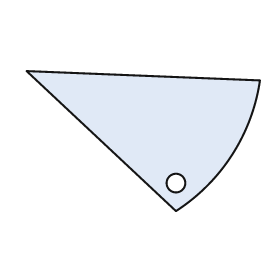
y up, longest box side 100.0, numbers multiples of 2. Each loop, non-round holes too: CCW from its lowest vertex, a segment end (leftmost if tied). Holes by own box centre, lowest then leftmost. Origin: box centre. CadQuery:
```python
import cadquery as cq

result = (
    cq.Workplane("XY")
    .moveTo(14.0, -30.0)
    .threePointArc((38.0, -6.0), (50.0, 26.0))
    .lineTo(-50.0, 30.0)
    .close()
    .moveTo(14.0, -18.0)
    .circle(4.0)
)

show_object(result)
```